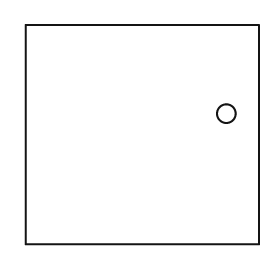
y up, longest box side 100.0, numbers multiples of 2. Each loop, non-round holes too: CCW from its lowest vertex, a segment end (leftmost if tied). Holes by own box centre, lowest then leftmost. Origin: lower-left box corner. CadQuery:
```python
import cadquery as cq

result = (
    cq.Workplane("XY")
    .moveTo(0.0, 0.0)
    .lineTo(100.0, 0.0)
    .lineTo(100.0, 94.0)
    .lineTo(0.0, 94.0)
    .close()
    .moveTo(86.0, 56.0)
    .circle(4.0)
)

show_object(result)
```